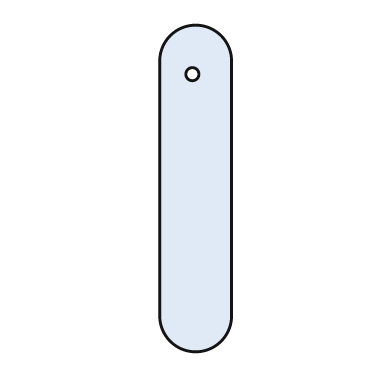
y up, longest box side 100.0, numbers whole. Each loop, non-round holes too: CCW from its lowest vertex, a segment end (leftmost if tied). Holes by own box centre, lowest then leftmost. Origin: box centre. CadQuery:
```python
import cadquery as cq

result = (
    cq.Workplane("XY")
    .moveTo(-11.0, -39.0)
    .threePointArc((0.0, -50.0), (11.0, -39.0))
    .lineTo(11.0, 39.0)
    .threePointArc((0.0, 50.0), (-11.0, 39.0))
    .close()
    .moveTo(-1.0, 35.0)
    .circle(2.0)
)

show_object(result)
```